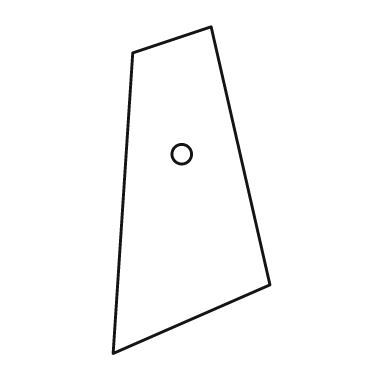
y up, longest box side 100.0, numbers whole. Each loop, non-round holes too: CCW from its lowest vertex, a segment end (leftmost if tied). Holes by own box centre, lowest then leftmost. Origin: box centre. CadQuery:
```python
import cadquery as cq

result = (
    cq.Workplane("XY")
    .moveTo(-24.0, -50.0)
    .lineTo(24.0, -29.0)
    .lineTo(6.0, 50.0)
    .lineTo(-18.0, 42.0)
    .close()
    .moveTo(-3.0, 11.0)
    .circle(3.0)
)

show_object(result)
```